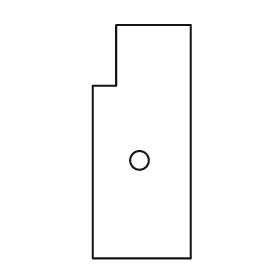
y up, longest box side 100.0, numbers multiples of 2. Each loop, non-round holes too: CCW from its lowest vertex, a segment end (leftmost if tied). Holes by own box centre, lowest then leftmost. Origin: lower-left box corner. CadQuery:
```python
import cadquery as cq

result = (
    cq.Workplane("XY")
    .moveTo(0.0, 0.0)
    .lineTo(42.0, 0.0)
    .lineTo(42.0, 100.0)
    .lineTo(10.0, 100.0)
    .lineTo(10.0, 74.0)
    .lineTo(0.0, 74.0)
    .close()
    .moveTo(20.0, 42.0)
    .circle(4.0)
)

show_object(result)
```